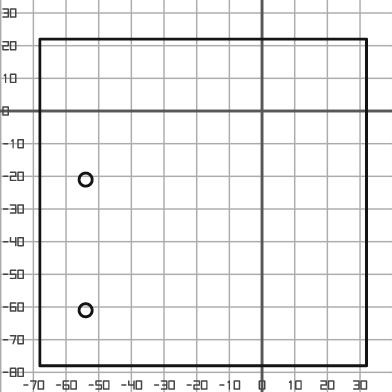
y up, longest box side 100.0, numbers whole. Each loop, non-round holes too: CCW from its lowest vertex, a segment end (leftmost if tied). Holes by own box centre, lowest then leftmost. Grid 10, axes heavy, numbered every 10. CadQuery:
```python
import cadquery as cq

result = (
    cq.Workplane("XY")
    .moveTo(-68.0, -78.0)
    .lineTo(32.0, -78.0)
    .lineTo(32.0, 22.0)
    .lineTo(-68.0, 22.0)
    .close()
    .moveTo(-54.0, -61.0)
    .circle(2.0)
    .moveTo(-54.0, -21.0)
    .circle(2.0)
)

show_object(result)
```